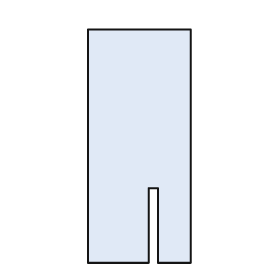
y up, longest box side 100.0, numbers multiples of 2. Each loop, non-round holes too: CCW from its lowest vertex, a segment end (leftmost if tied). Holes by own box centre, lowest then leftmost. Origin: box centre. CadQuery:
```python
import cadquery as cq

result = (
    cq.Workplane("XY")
    .moveTo(-22.0, -50.0)
    .lineTo(4.0, -50.0)
    .lineTo(4.0, -18.0)
    .lineTo(8.0, -18.0)
    .lineTo(8.0, -50.0)
    .lineTo(22.0, -50.0)
    .lineTo(22.0, 50.0)
    .lineTo(-22.0, 50.0)
    .close()
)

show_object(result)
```